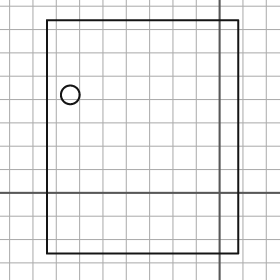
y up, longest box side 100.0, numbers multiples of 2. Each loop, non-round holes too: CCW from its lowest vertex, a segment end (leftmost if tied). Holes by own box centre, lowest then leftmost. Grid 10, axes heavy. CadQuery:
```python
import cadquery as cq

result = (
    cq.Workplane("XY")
    .moveTo(-74.0, -26.0)
    .lineTo(8.0, -26.0)
    .lineTo(8.0, 74.0)
    .lineTo(-74.0, 74.0)
    .close()
    .moveTo(-64.0, 42.0)
    .circle(4.0)
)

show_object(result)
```